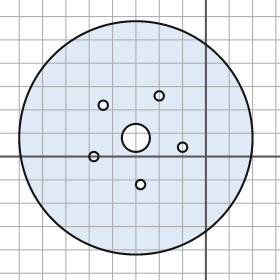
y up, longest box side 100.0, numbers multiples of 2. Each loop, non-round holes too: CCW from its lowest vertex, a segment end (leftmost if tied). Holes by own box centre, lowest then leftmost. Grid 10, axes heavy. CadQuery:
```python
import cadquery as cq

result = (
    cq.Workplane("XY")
    .moveTo(-30.0, 8.0)
    .circle(50.0)
    .moveTo(-28.0, -12.0)
    .circle(2.0)
    .moveTo(-48.0, 0.0)
    .circle(2.0)
    .moveTo(-10.0, 4.0)
    .circle(2.0)
    .moveTo(-30.0, 8.0)
    .circle(6.0)
    .moveTo(-44.0, 22.0)
    .circle(2.0)
    .moveTo(-20.0, 26.0)
    .circle(2.0)
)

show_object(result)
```